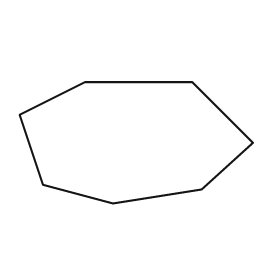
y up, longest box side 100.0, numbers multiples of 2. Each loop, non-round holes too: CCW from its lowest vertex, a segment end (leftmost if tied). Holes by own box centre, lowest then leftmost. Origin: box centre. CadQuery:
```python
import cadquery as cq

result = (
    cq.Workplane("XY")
    .moveTo(-10.0, -26.0)
    .lineTo(28.0, -20.0)
    .lineTo(50.0, 0.0)
    .lineTo(24.0, 26.0)
    .lineTo(-22.0, 26.0)
    .lineTo(-50.0, 12.0)
    .lineTo(-40.0, -18.0)
    .close()
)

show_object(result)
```